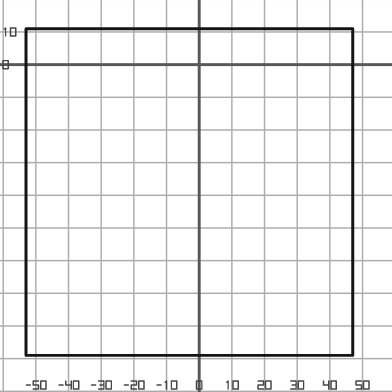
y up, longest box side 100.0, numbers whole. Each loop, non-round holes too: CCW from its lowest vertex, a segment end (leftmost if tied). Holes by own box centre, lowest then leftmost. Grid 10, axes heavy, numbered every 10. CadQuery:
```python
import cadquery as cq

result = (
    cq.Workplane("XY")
    .moveTo(-53.0, -89.0)
    .lineTo(47.0, -89.0)
    .lineTo(47.0, 11.0)
    .lineTo(-53.0, 11.0)
    .close()
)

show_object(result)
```